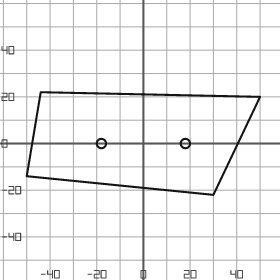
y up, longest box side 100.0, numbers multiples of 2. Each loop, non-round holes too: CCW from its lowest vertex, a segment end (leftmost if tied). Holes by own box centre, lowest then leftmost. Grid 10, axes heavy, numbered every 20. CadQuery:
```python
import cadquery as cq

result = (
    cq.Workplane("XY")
    .moveTo(30.0, -22.0)
    .lineTo(50.0, 20.0)
    .lineTo(-44.0, 22.0)
    .lineTo(-50.0, -14.0)
    .close()
    .moveTo(-18.0, 0.0)
    .circle(2.0)
    .moveTo(18.0, 0.0)
    .circle(2.0)
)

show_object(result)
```